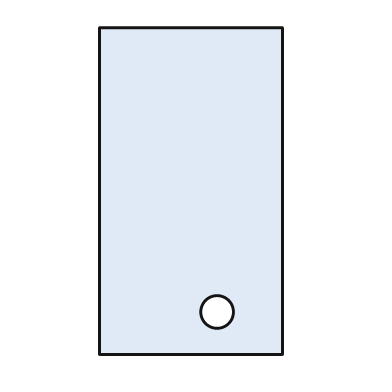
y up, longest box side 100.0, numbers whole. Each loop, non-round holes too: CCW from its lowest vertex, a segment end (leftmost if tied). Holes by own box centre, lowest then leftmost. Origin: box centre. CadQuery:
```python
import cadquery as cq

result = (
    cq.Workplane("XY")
    .moveTo(-28.0, -50.0)
    .lineTo(28.0, -50.0)
    .lineTo(28.0, 50.0)
    .lineTo(-28.0, 50.0)
    .close()
    .moveTo(8.0, -37.0)
    .circle(5.0)
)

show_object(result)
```